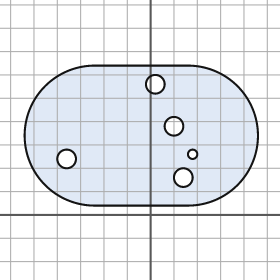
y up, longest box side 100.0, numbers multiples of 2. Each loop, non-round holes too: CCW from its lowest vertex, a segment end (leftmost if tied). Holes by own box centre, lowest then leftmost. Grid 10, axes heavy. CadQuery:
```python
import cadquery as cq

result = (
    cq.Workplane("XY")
    .moveTo(-24.0, 4.0)
    .lineTo(16.0, 4.0)
    .threePointArc((46.0, 34.0), (16.0, 64.0))
    .lineTo(-24.0, 64.0)
    .threePointArc((-54.0, 34.0), (-24.0, 4.0))
    .close()
    .moveTo(14.0, 16.0)
    .circle(4.0)
    .moveTo(-36.0, 24.0)
    .circle(4.0)
    .moveTo(18.0, 26.0)
    .circle(2.0)
    .moveTo(10.0, 38.0)
    .circle(4.0)
    .moveTo(2.0, 56.0)
    .circle(4.0)
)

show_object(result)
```